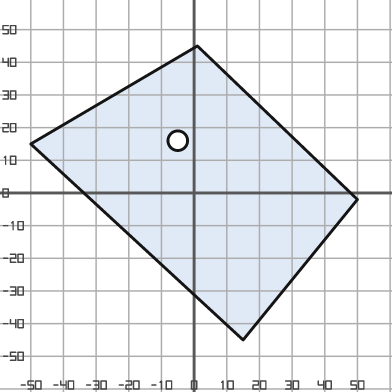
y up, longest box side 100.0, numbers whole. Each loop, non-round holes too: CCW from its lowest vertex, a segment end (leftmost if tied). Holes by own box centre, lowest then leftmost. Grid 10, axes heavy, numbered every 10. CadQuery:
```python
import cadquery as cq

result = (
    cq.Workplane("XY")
    .moveTo(15.0, -45.0)
    .lineTo(50.0, -2.0)
    .lineTo(1.0, 45.0)
    .lineTo(-50.0, 15.0)
    .close()
    .moveTo(-5.0, 16.0)
    .circle(3.0)
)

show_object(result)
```